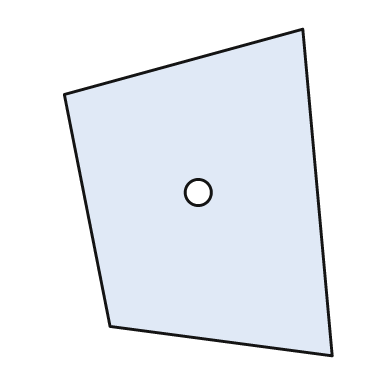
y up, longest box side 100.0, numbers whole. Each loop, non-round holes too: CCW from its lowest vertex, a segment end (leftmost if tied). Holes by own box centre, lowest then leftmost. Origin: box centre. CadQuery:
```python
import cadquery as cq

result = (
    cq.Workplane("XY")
    .moveTo(41.0, -50.0)
    .lineTo(32.0, 50.0)
    .lineTo(-41.0, 30.0)
    .lineTo(-27.0, -41.0)
    .close()
    .moveTo(0.0, 0.0)
    .circle(4.0)
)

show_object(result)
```